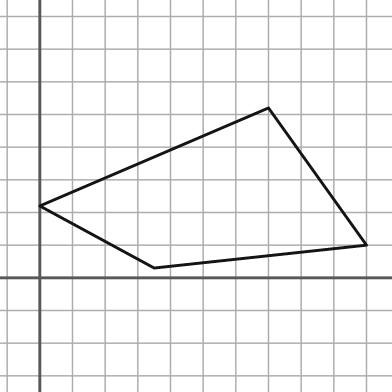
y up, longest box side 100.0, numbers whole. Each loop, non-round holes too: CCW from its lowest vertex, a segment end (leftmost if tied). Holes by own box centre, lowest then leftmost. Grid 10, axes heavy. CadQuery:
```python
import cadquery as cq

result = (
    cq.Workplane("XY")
    .moveTo(35.0, 3.0)
    .lineTo(100.0, 10.0)
    .lineTo(70.0, 52.0)
    .lineTo(0.0, 22.0)
    .close()
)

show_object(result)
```